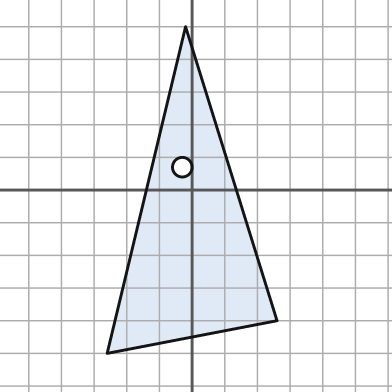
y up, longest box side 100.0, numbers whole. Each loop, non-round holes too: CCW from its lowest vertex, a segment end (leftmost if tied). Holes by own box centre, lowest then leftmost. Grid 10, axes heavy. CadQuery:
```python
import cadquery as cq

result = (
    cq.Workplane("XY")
    .moveTo(-26.0, -50.0)
    .lineTo(26.0, -40.0)
    .lineTo(-2.0, 50.0)
    .close()
    .moveTo(-3.0, 7.0)
    .circle(3.0)
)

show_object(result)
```